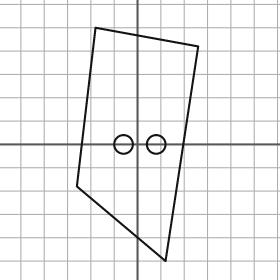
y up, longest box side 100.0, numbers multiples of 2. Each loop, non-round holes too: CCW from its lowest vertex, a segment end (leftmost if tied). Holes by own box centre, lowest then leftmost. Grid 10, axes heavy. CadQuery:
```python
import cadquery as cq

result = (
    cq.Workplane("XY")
    .moveTo(12.0, -50.0)
    .lineTo(26.0, 42.0)
    .lineTo(-18.0, 50.0)
    .lineTo(-26.0, -18.0)
    .close()
    .moveTo(-6.0, 0.0)
    .circle(4.0)
    .moveTo(8.0, 0.0)
    .circle(4.0)
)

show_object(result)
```